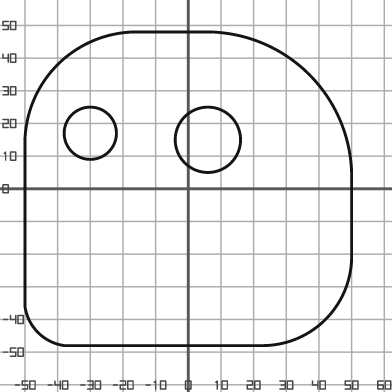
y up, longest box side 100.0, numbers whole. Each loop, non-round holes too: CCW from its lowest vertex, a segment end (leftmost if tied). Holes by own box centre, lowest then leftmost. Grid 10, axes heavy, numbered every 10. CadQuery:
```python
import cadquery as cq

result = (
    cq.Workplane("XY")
    .moveTo(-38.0, -48.0)
    .lineTo(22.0, -48.0)
    .threePointArc((42.0, -40.0), (50.0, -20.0))
    .lineTo(50.0, 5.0)
    .threePointArc((37.0, 35.0), (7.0, 48.0))
    .lineTo(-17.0, 48.0)
    .threePointArc((-40.0, 38.0), (-50.0, 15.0))
    .lineTo(-50.0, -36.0)
    .threePointArc((-46.0, -44.0), (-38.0, -48.0))
    .close()
    .moveTo(6.0, 15.0)
    .circle(10.0)
    .moveTo(-30.0, 17.0)
    .circle(8.0)
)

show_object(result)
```